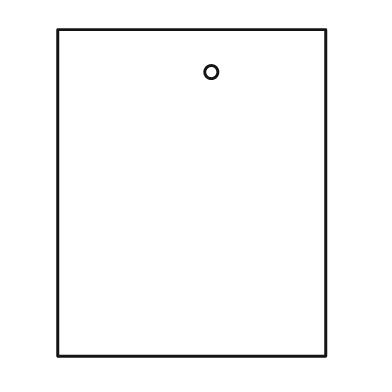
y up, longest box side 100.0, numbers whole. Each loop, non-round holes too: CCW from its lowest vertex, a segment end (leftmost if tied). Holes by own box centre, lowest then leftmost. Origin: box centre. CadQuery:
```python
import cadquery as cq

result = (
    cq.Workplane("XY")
    .moveTo(-41.0, -50.0)
    .lineTo(41.0, -50.0)
    .lineTo(41.0, 50.0)
    .lineTo(-41.0, 50.0)
    .close()
    .moveTo(6.0, 37.0)
    .circle(2.0)
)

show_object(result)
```